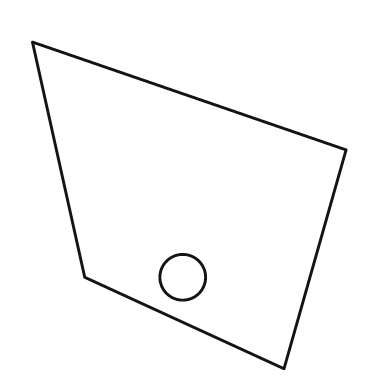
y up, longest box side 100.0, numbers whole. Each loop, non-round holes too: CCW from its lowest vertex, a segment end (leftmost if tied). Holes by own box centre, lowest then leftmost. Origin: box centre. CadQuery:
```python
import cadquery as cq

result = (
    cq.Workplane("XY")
    .moveTo(29.0, -50.0)
    .lineTo(48.0, 17.0)
    .lineTo(-48.0, 50.0)
    .lineTo(-32.0, -22.0)
    .close()
    .moveTo(-2.0, -22.0)
    .circle(7.0)
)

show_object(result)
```